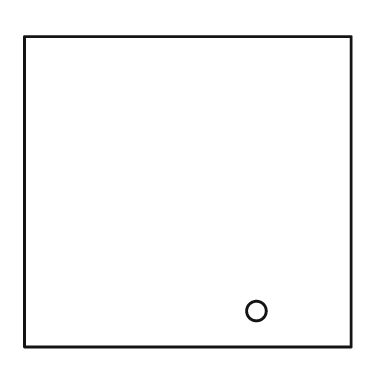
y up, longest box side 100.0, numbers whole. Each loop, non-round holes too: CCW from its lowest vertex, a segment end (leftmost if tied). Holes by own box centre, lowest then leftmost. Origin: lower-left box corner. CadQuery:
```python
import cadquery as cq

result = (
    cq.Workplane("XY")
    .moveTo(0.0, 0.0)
    .lineTo(100.0, 0.0)
    .lineTo(100.0, 95.0)
    .lineTo(0.0, 95.0)
    .close()
    .moveTo(71.0, 11.0)
    .circle(3.0)
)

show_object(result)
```